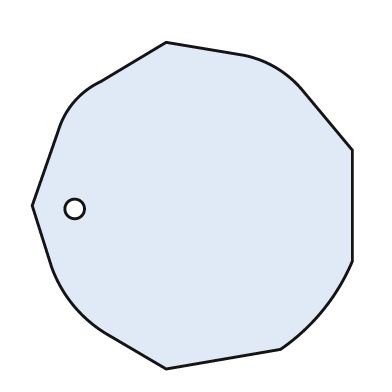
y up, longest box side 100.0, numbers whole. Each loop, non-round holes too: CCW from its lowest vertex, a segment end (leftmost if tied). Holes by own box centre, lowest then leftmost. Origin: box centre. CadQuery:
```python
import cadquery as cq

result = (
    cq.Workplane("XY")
    .moveTo(-8.0, -50.0)
    .lineTo(27.0, -44.0)
    .threePointArc((40.0, -32.0), (49.0, -17.0))
    .lineTo(49.0, 17.0)
    .lineTo(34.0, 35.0)
    .threePointArc((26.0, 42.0), (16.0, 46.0))
    .lineTo(-8.0, 50.0)
    .lineTo(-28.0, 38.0)
    .threePointArc((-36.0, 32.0), (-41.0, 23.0))
    .lineTo(-49.0, 0.0)
    .lineTo(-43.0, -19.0)
    .threePointArc((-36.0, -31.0), (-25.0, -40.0))
    .close()
    .moveTo(-36.0, -1.0)
    .circle(3.0)
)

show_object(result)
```